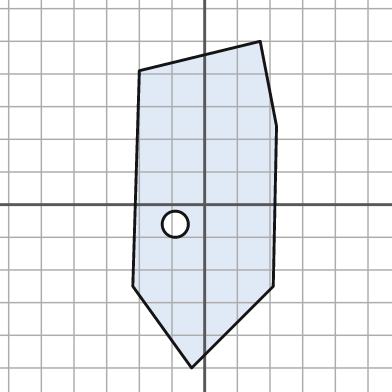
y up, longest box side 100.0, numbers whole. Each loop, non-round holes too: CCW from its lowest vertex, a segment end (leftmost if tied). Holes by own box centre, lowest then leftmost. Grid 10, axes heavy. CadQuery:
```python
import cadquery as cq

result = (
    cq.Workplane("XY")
    .moveTo(-4.0, -50.0)
    .lineTo(21.0, -25.0)
    .lineTo(22.0, 24.0)
    .lineTo(17.0, 50.0)
    .lineTo(-20.0, 41.0)
    .lineTo(-22.0, -25.0)
    .close()
    .moveTo(-9.0, -6.0)
    .circle(4.0)
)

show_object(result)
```